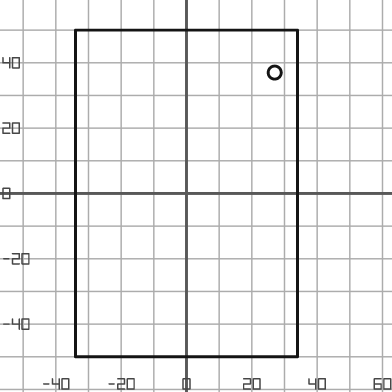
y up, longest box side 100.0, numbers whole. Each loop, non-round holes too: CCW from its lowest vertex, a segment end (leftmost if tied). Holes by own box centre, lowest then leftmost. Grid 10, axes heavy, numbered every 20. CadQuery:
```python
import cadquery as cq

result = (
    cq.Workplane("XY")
    .moveTo(-34.0, -50.0)
    .lineTo(34.0, -50.0)
    .lineTo(34.0, 50.0)
    .lineTo(-34.0, 50.0)
    .close()
    .moveTo(27.0, 37.0)
    .circle(2.0)
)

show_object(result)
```